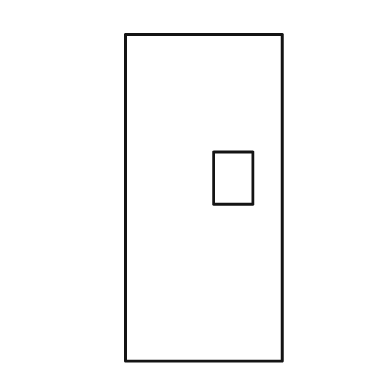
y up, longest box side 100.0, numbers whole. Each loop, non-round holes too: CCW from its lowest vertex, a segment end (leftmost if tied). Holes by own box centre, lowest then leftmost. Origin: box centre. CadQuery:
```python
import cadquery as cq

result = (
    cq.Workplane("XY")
    .moveTo(-24.0, -50.0)
    .lineTo(24.0, -50.0)
    .lineTo(24.0, 50.0)
    .lineTo(-24.0, 50.0)
    .close()
    .moveTo(3.0, -2.0)
    .lineTo(15.0, -2.0)
    .lineTo(15.0, 14.0)
    .lineTo(3.0, 14.0)
    .close()
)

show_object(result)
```